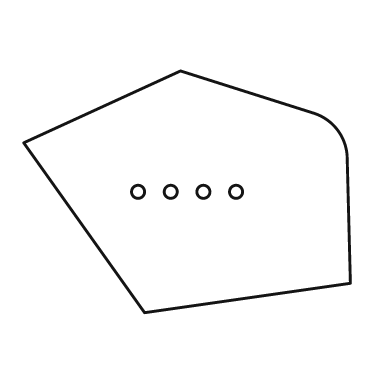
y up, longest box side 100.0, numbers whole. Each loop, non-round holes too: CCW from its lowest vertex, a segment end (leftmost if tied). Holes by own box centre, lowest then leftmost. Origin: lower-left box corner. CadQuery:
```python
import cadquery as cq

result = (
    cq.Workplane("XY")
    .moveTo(37.0, 0.0)
    .lineTo(100.0, 9.0)
    .lineTo(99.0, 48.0)
    .threePointArc((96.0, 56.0), (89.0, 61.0))
    .lineTo(48.0, 74.0)
    .lineTo(0.0, 52.0)
    .close()
    .moveTo(35.0, 37.0)
    .circle(2.0)
    .moveTo(45.0, 37.0)
    .circle(2.0)
    .moveTo(55.0, 37.0)
    .circle(2.0)
    .moveTo(65.0, 37.0)
    .circle(2.0)
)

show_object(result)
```